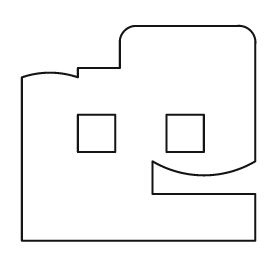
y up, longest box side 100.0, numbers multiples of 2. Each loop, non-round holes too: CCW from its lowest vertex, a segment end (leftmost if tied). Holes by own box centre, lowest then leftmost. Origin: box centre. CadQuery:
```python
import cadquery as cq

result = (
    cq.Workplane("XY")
    .moveTo(-50.0, -46.0)
    .lineTo(50.0, -46.0)
    .lineTo(50.0, -26.0)
    .lineTo(6.0, -26.0)
    .lineTo(6.0, -12.0)
    .threePointArc((28.0, -18.0), (50.0, -12.0))
    .lineTo(50.0, 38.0)
    .threePointArc((48.0, 44.0), (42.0, 46.0))
    .lineTo(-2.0, 46.0)
    .threePointArc((-6.0, 44.0), (-8.0, 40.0))
    .lineTo(-8.0, 28.0)
    .lineTo(-26.0, 28.0)
    .lineTo(-26.0, 24.0)
    .threePointArc((-38.0, 26.0), (-50.0, 24.0))
    .close()
    .moveTo(-26.0, -8.0)
    .lineTo(-10.0, -8.0)
    .lineTo(-10.0, 8.0)
    .lineTo(-26.0, 8.0)
    .close()
    .moveTo(12.0, -8.0)
    .lineTo(28.0, -8.0)
    .lineTo(28.0, 8.0)
    .lineTo(12.0, 8.0)
    .close()
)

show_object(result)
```